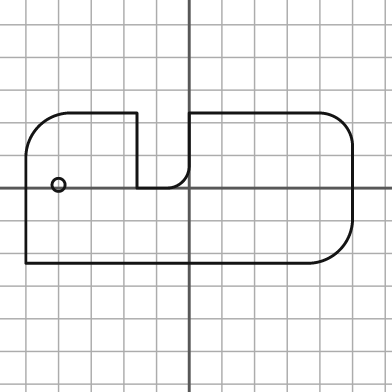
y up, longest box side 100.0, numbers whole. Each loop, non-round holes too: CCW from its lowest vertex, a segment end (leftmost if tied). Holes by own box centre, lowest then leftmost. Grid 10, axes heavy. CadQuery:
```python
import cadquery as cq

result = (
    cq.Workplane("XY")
    .moveTo(-50.0, -23.0)
    .lineTo(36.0, -23.0)
    .threePointArc((46.0, -19.0), (50.0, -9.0))
    .lineTo(50.0, 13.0)
    .threePointArc((47.0, 20.0), (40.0, 23.0))
    .lineTo(0.0, 23.0)
    .lineTo(0.0, 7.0)
    .threePointArc((-2.0, 2.0), (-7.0, 0.0))
    .lineTo(-16.0, 0.0)
    .lineTo(-16.0, 23.0)
    .lineTo(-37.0, 23.0)
    .threePointArc((-46.0, 19.0), (-50.0, 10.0))
    .close()
    .moveTo(-40.0, 1.0)
    .circle(2.0)
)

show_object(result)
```